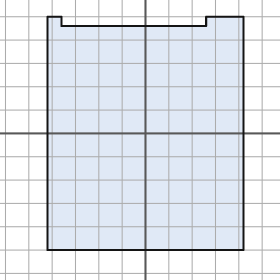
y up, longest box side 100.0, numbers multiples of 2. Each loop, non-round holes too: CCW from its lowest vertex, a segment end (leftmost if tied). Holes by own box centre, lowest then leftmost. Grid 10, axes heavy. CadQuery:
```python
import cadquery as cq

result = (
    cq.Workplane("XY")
    .moveTo(-42.0, -50.0)
    .lineTo(42.0, -50.0)
    .lineTo(42.0, 50.0)
    .lineTo(26.0, 50.0)
    .lineTo(26.0, 46.0)
    .lineTo(-36.0, 46.0)
    .lineTo(-36.0, 50.0)
    .lineTo(-42.0, 50.0)
    .close()
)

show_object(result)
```